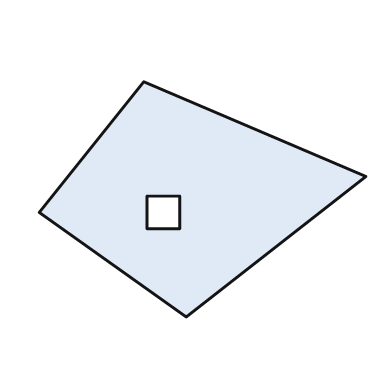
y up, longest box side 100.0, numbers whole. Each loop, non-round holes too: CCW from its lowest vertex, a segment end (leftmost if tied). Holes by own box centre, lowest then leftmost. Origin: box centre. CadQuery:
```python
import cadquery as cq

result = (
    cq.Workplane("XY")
    .moveTo(-5.0, -36.0)
    .lineTo(50.0, 7.0)
    .lineTo(-18.0, 36.0)
    .lineTo(-50.0, -4.0)
    .close()
    .moveTo(-17.0, -9.0)
    .lineTo(-7.0, -9.0)
    .lineTo(-7.0, 1.0)
    .lineTo(-17.0, 1.0)
    .close()
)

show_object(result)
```